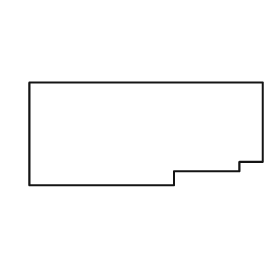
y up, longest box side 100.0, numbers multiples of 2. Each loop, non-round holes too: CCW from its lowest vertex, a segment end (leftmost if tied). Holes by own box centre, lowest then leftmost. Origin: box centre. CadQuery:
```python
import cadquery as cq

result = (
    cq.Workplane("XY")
    .moveTo(-50.0, -22.0)
    .lineTo(12.0, -22.0)
    .lineTo(12.0, -16.0)
    .lineTo(40.0, -16.0)
    .lineTo(40.0, -12.0)
    .lineTo(50.0, -12.0)
    .lineTo(50.0, 22.0)
    .lineTo(-50.0, 22.0)
    .close()
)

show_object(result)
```